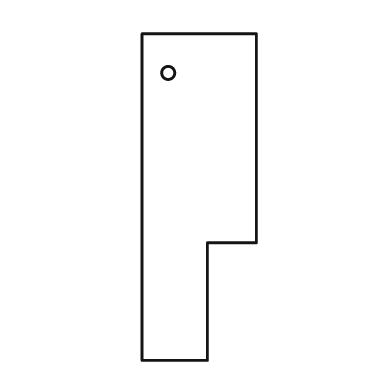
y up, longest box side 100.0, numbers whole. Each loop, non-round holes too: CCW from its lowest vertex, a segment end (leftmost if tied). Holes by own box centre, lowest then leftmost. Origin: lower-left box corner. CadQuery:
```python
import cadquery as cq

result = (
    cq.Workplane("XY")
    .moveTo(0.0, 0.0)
    .lineTo(20.0, 0.0)
    .lineTo(20.0, 36.0)
    .lineTo(35.0, 36.0)
    .lineTo(35.0, 100.0)
    .lineTo(0.0, 100.0)
    .close()
    .moveTo(8.0, 88.0)
    .circle(2.0)
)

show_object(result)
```